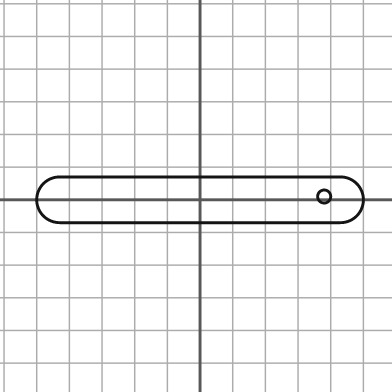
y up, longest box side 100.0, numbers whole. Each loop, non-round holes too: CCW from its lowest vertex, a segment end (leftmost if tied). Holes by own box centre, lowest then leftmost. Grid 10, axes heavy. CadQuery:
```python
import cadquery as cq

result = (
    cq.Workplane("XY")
    .moveTo(-43.0, -7.0)
    .lineTo(43.0, -7.0)
    .threePointArc((50.0, 0.0), (43.0, 7.0))
    .lineTo(-43.0, 7.0)
    .threePointArc((-50.0, 0.0), (-43.0, -7.0))
    .close()
    .moveTo(38.0, 1.0)
    .circle(2.0)
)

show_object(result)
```